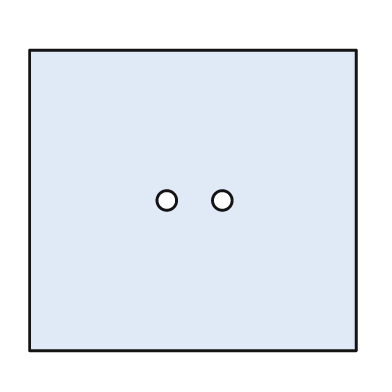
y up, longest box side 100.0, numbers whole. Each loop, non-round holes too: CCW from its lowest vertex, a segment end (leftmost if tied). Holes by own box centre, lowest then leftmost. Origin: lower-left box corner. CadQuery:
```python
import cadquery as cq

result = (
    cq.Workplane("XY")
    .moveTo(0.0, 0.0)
    .lineTo(100.0, 0.0)
    .lineTo(100.0, 92.0)
    .lineTo(0.0, 92.0)
    .close()
    .moveTo(42.0, 46.0)
    .circle(3.0)
    .moveTo(59.0, 46.0)
    .circle(3.0)
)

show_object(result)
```